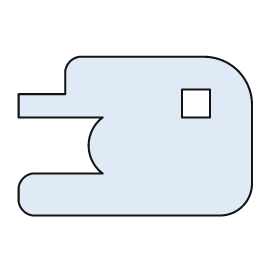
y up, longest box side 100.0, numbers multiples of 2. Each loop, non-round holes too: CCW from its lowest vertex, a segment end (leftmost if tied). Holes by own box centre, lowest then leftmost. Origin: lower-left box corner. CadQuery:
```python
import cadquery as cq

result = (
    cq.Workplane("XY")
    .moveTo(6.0, 0.0)
    .lineTo(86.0, 0.0)
    .threePointArc((96.0, 4.0), (100.0, 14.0))
    .lineTo(100.0, 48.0)
    .threePointArc((94.0, 62.0), (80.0, 68.0))
    .lineTo(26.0, 68.0)
    .threePointArc((22.0, 66.0), (20.0, 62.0))
    .lineTo(20.0, 52.0)
    .lineTo(0.0, 52.0)
    .lineTo(0.0, 42.0)
    .lineTo(36.0, 42.0)
    .threePointArc((30.0, 30.0), (36.0, 18.0))
    .lineTo(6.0, 18.0)
    .threePointArc((2.0, 16.0), (0.0, 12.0))
    .lineTo(0.0, 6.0)
    .threePointArc((2.0, 2.0), (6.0, 0.0))
    .close()
    .moveTo(70.0, 42.0)
    .lineTo(82.0, 42.0)
    .lineTo(82.0, 54.0)
    .lineTo(70.0, 54.0)
    .close()
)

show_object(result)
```